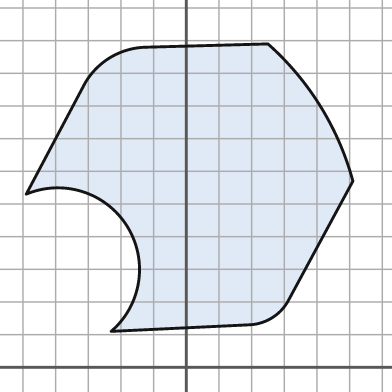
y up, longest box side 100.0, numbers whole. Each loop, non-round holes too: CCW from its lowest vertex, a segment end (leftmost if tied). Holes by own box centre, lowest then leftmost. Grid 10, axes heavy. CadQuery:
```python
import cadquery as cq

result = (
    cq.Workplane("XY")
    .moveTo(-23.0, 11.0)
    .lineTo(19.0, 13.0)
    .threePointArc((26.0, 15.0), (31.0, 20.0))
    .lineTo(51.0, 57.0)
    .threePointArc((41.0, 80.0), (25.0, 99.0))
    .lineTo(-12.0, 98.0)
    .threePointArc((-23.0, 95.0), (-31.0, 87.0))
    .lineTo(-49.0, 53.0)
    .threePointArc((-18.0, 43.0), (-23.0, 11.0))
    .close()
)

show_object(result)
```